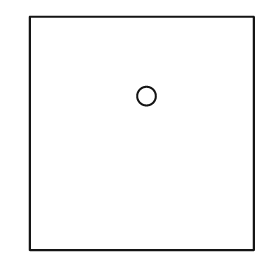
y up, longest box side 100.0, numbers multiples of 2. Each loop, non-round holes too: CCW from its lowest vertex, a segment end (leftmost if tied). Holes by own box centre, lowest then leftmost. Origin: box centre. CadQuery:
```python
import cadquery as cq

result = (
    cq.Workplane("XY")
    .moveTo(-48.0, -50.0)
    .lineTo(48.0, -50.0)
    .lineTo(48.0, 50.0)
    .lineTo(-48.0, 50.0)
    .close()
    .moveTo(2.0, 16.0)
    .circle(4.0)
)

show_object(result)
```